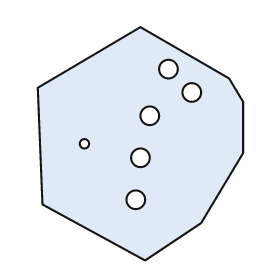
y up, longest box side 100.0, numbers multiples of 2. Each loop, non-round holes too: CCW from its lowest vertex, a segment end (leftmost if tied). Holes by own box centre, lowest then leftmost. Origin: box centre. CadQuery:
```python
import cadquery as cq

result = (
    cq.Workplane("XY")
    .moveTo(2.0, -50.0)
    .lineTo(26.0, -34.0)
    .lineTo(44.0, -4.0)
    .lineTo(44.0, 18.0)
    .lineTo(38.0, 28.0)
    .lineTo(0.0, 50.0)
    .lineTo(-44.0, 24.0)
    .lineTo(-42.0, -26.0)
    .close()
    .moveTo(-2.0, -24.0)
    .circle(4.0)
    .moveTo(0.0, -6.0)
    .circle(4.0)
    .moveTo(-24.0, 0.0)
    .circle(2.0)
    .moveTo(4.0, 12.0)
    .circle(4.0)
    .moveTo(22.0, 22.0)
    .circle(4.0)
    .moveTo(12.0, 32.0)
    .circle(4.0)
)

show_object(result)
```